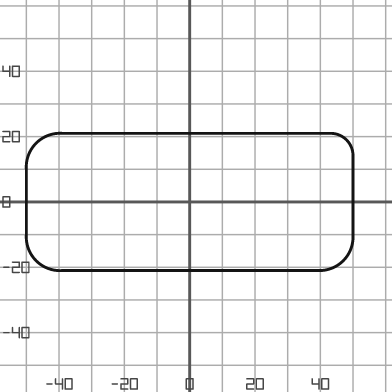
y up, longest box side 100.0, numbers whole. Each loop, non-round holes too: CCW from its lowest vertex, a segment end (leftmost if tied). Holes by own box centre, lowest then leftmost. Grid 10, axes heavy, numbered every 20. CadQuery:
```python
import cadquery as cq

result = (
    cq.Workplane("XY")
    .moveTo(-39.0, -21.0)
    .lineTo(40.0, -21.0)
    .threePointArc((47.0, -18.0), (50.0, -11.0))
    .lineTo(50.0, 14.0)
    .threePointArc((48.0, 19.0), (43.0, 21.0))
    .lineTo(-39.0, 21.0)
    .threePointArc((-47.0, 18.0), (-50.0, 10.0))
    .lineTo(-50.0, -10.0)
    .threePointArc((-47.0, -18.0), (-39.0, -21.0))
    .close()
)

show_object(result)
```